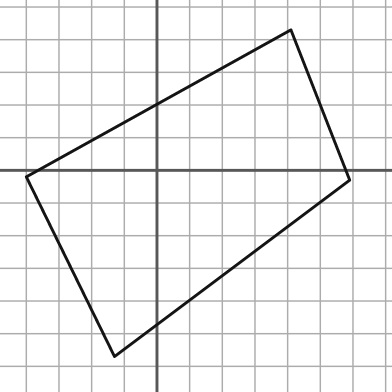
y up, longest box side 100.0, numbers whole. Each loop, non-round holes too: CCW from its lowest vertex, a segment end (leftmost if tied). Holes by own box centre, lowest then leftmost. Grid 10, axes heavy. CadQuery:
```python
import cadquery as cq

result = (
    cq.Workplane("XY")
    .moveTo(-13.0, -57.0)
    .lineTo(59.0, -3.0)
    .lineTo(41.0, 43.0)
    .lineTo(-40.0, -2.0)
    .close()
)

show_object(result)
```